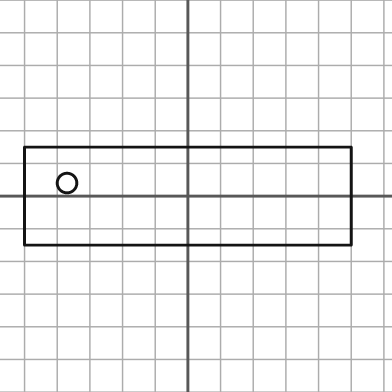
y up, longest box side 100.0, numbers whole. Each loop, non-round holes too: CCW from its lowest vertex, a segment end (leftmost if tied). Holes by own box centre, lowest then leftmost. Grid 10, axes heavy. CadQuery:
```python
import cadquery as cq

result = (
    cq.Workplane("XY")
    .moveTo(-50.0, -15.0)
    .lineTo(50.0, -15.0)
    .lineTo(50.0, 15.0)
    .lineTo(-50.0, 15.0)
    .close()
    .moveTo(-37.0, 4.0)
    .circle(3.0)
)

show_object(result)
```